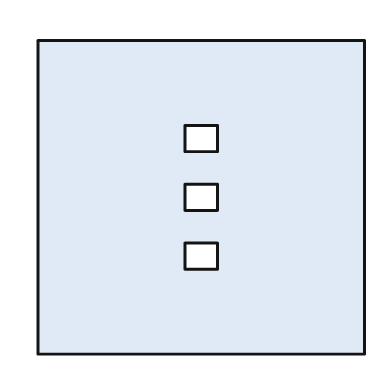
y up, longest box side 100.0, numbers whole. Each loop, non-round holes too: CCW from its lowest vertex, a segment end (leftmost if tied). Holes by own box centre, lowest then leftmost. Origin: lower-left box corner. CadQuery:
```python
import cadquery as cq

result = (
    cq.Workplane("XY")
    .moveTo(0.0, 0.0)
    .lineTo(100.0, 0.0)
    .lineTo(100.0, 96.0)
    .lineTo(0.0, 96.0)
    .close()
    .moveTo(45.0, 26.0)
    .lineTo(55.0, 26.0)
    .lineTo(55.0, 34.0)
    .lineTo(45.0, 34.0)
    .close()
    .moveTo(45.0, 44.0)
    .lineTo(55.0, 44.0)
    .lineTo(55.0, 52.0)
    .lineTo(45.0, 52.0)
    .close()
    .moveTo(45.0, 62.0)
    .lineTo(55.0, 62.0)
    .lineTo(55.0, 70.0)
    .lineTo(45.0, 70.0)
    .close()
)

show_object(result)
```